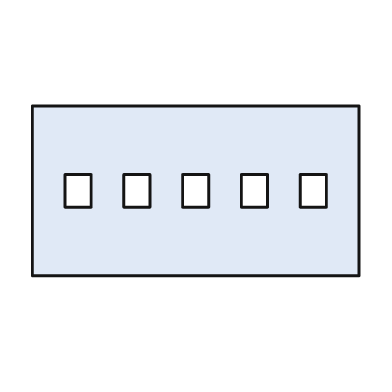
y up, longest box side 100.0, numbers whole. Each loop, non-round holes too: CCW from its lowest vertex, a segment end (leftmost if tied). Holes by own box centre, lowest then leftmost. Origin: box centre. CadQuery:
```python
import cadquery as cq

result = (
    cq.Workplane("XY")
    .moveTo(-50.0, -26.0)
    .lineTo(50.0, -26.0)
    .lineTo(50.0, 26.0)
    .lineTo(-50.0, 26.0)
    .close()
    .moveTo(-40.0, -5.0)
    .lineTo(-32.0, -5.0)
    .lineTo(-32.0, 5.0)
    .lineTo(-40.0, 5.0)
    .close()
    .moveTo(-22.0, -5.0)
    .lineTo(-14.0, -5.0)
    .lineTo(-14.0, 5.0)
    .lineTo(-22.0, 5.0)
    .close()
    .moveTo(-4.0, -5.0)
    .lineTo(4.0, -5.0)
    .lineTo(4.0, 5.0)
    .lineTo(-4.0, 5.0)
    .close()
    .moveTo(14.0, -5.0)
    .lineTo(22.0, -5.0)
    .lineTo(22.0, 5.0)
    .lineTo(14.0, 5.0)
    .close()
    .moveTo(32.0, -5.0)
    .lineTo(40.0, -5.0)
    .lineTo(40.0, 5.0)
    .lineTo(32.0, 5.0)
    .close()
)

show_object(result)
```